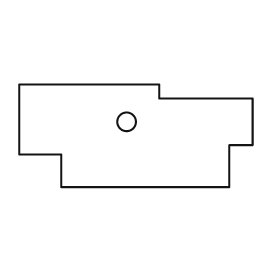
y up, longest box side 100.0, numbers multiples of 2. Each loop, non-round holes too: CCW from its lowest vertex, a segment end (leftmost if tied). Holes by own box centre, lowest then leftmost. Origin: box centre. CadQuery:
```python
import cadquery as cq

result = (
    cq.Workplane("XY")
    .moveTo(-32.0, -22.0)
    .lineTo(40.0, -22.0)
    .lineTo(40.0, -4.0)
    .lineTo(50.0, -4.0)
    .lineTo(50.0, 16.0)
    .lineTo(10.0, 16.0)
    .lineTo(10.0, 22.0)
    .lineTo(-50.0, 22.0)
    .lineTo(-50.0, -8.0)
    .lineTo(-32.0, -8.0)
    .close()
    .moveTo(-4.0, 6.0)
    .circle(4.0)
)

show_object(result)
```